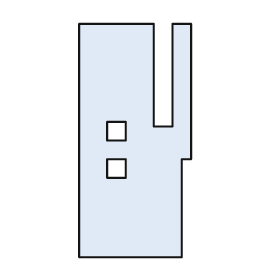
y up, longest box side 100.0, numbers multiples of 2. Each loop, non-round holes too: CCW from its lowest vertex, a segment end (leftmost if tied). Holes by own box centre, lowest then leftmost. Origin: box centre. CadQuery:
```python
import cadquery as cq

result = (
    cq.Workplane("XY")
    .moveTo(-24.0, -50.0)
    .lineTo(20.0, -50.0)
    .lineTo(20.0, -8.0)
    .lineTo(24.0, -8.0)
    .lineTo(24.0, 50.0)
    .lineTo(16.0, 50.0)
    .lineTo(16.0, 6.0)
    .lineTo(8.0, 6.0)
    .lineTo(8.0, 50.0)
    .lineTo(-24.0, 50.0)
    .close()
    .moveTo(-12.0, -16.0)
    .lineTo(-4.0, -16.0)
    .lineTo(-4.0, -8.0)
    .lineTo(-12.0, -8.0)
    .close()
    .moveTo(-12.0, 0.0)
    .lineTo(-4.0, 0.0)
    .lineTo(-4.0, 8.0)
    .lineTo(-12.0, 8.0)
    .close()
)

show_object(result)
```